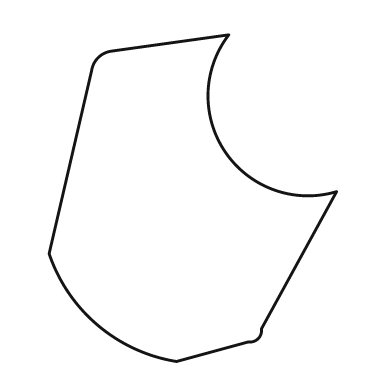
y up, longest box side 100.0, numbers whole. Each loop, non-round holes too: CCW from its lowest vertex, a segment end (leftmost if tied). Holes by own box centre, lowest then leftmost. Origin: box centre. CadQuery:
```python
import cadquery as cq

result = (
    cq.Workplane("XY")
    .moveTo(-5.0, -50.0)
    .lineTo(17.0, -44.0)
    .threePointArc((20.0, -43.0), (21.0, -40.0))
    .lineTo(44.0, 2.0)
    .threePointArc((10.0, 14.0), (11.0, 50.0))
    .lineTo(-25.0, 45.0)
    .threePointArc((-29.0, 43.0), (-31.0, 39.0))
    .lineTo(-44.0, -17.0)
    .threePointArc((-29.0, -39.0), (-5.0, -50.0))
    .close()
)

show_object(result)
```